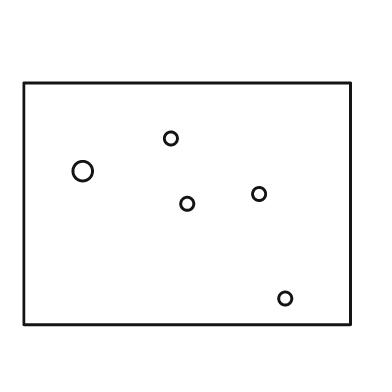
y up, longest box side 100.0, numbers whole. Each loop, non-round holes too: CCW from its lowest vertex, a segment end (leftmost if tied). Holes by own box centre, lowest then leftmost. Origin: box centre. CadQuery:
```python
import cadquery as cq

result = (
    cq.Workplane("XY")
    .moveTo(-50.0, -37.0)
    .lineTo(50.0, -37.0)
    .lineTo(50.0, 37.0)
    .lineTo(-50.0, 37.0)
    .close()
    .moveTo(30.0, -29.0)
    .circle(2.0)
    .moveTo(0.0, 0.0)
    .circle(2.0)
    .moveTo(22.0, 3.0)
    .circle(2.0)
    .moveTo(-32.0, 10.0)
    .circle(3.0)
    .moveTo(-5.0, 20.0)
    .circle(2.0)
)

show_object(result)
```